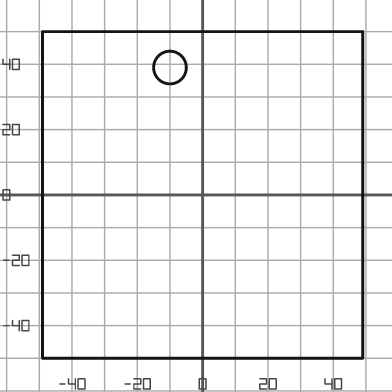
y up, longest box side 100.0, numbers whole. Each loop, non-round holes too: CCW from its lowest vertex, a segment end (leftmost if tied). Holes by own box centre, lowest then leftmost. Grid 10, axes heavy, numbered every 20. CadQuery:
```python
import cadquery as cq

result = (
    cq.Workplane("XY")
    .moveTo(-49.0, -50.0)
    .lineTo(49.0, -50.0)
    .lineTo(49.0, 50.0)
    .lineTo(-49.0, 50.0)
    .close()
    .moveTo(-10.0, 39.0)
    .circle(5.0)
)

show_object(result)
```